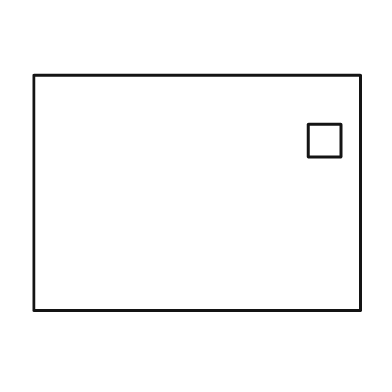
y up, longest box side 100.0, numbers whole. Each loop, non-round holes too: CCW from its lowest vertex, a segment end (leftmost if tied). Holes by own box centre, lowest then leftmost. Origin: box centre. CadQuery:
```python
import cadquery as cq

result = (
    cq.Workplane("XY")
    .moveTo(-50.0, -36.0)
    .lineTo(50.0, -36.0)
    .lineTo(50.0, 36.0)
    .lineTo(-50.0, 36.0)
    .close()
    .moveTo(34.0, 11.0)
    .lineTo(44.0, 11.0)
    .lineTo(44.0, 21.0)
    .lineTo(34.0, 21.0)
    .close()
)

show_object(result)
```